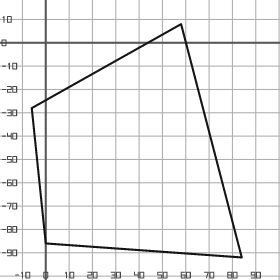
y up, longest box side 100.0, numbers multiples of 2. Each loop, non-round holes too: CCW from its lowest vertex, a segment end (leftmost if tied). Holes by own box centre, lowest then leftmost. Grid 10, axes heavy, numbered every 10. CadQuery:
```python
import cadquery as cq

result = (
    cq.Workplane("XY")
    .moveTo(84.0, -92.0)
    .lineTo(58.0, 8.0)
    .lineTo(-6.0, -28.0)
    .lineTo(0.0, -86.0)
    .close()
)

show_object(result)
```